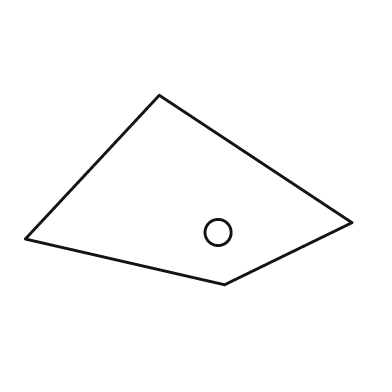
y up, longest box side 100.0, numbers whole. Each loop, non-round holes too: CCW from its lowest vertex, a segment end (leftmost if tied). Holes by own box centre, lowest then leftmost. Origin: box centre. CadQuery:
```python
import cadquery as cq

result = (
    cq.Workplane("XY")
    .moveTo(11.0, -29.0)
    .lineTo(50.0, -10.0)
    .lineTo(-9.0, 29.0)
    .lineTo(-50.0, -15.0)
    .close()
    .moveTo(9.0, -13.0)
    .circle(4.0)
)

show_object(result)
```